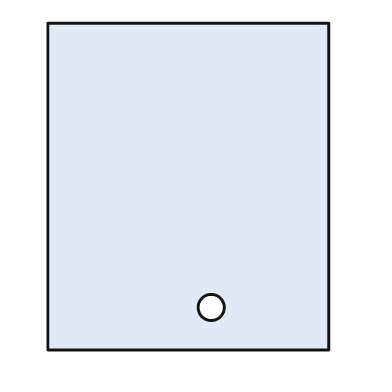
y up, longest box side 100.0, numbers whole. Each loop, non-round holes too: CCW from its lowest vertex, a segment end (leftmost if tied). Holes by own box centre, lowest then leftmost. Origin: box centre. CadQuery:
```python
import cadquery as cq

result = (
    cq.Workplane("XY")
    .moveTo(-43.0, -50.0)
    .lineTo(43.0, -50.0)
    .lineTo(43.0, 50.0)
    .lineTo(-43.0, 50.0)
    .close()
    .moveTo(7.0, -37.0)
    .circle(4.0)
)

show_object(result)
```